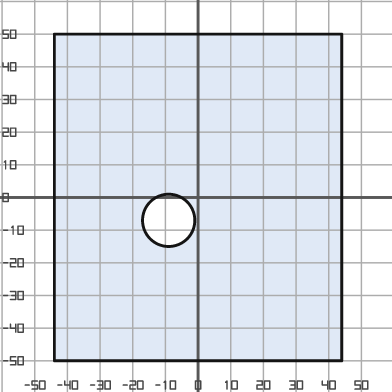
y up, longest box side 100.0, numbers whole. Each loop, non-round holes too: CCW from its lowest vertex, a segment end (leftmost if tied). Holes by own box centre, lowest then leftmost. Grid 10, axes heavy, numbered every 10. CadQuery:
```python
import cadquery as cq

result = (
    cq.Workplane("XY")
    .moveTo(-44.0, -50.0)
    .lineTo(44.0, -50.0)
    .lineTo(44.0, 50.0)
    .lineTo(-44.0, 50.0)
    .close()
    .moveTo(-9.0, -7.0)
    .circle(8.0)
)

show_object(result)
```